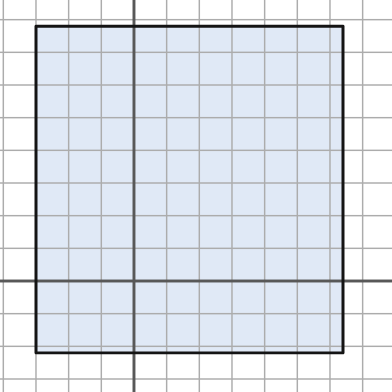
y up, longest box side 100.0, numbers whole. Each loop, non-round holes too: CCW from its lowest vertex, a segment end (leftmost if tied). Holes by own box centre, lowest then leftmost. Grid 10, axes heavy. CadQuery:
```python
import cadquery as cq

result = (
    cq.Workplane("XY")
    .moveTo(-30.0, -22.0)
    .lineTo(64.0, -22.0)
    .lineTo(64.0, 78.0)
    .lineTo(-30.0, 78.0)
    .close()
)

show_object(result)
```